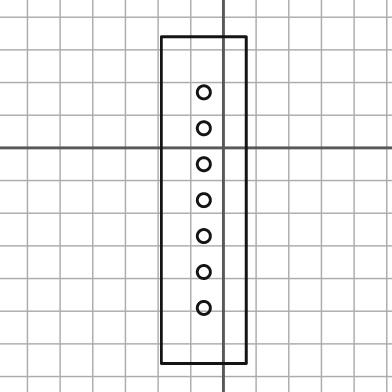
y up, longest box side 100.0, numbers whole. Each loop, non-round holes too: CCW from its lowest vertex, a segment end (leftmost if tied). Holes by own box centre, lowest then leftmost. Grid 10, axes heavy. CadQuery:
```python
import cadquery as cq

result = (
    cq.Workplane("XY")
    .moveTo(-19.0, -66.0)
    .lineTo(7.0, -66.0)
    .lineTo(7.0, 34.0)
    .lineTo(-19.0, 34.0)
    .close()
    .moveTo(-6.0, -49.0)
    .circle(2.0)
    .moveTo(-6.0, -38.0)
    .circle(2.0)
    .moveTo(-6.0, -27.0)
    .circle(2.0)
    .moveTo(-6.0, -16.0)
    .circle(2.0)
    .moveTo(-6.0, -5.0)
    .circle(2.0)
    .moveTo(-6.0, 6.0)
    .circle(2.0)
    .moveTo(-6.0, 17.0)
    .circle(2.0)
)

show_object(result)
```